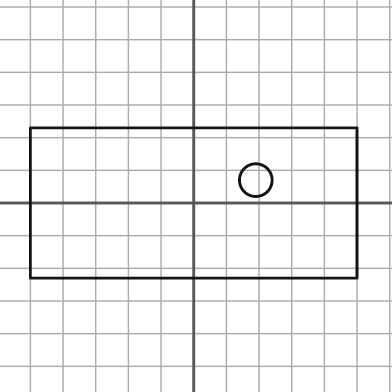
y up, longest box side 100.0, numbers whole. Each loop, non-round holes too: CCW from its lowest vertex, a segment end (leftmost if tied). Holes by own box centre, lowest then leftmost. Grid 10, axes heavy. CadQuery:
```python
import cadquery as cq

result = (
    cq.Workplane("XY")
    .moveTo(-50.0, -23.0)
    .lineTo(50.0, -23.0)
    .lineTo(50.0, 23.0)
    .lineTo(-50.0, 23.0)
    .close()
    .moveTo(19.0, 7.0)
    .circle(5.0)
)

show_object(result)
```